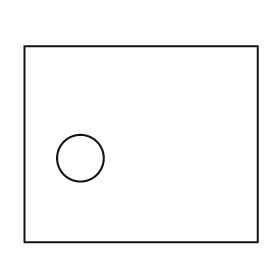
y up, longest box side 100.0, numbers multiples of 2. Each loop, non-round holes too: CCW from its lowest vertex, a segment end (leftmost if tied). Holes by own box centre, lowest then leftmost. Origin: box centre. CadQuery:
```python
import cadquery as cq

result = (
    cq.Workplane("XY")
    .moveTo(-50.0, -42.0)
    .lineTo(50.0, -42.0)
    .lineTo(50.0, 42.0)
    .lineTo(-50.0, 42.0)
    .close()
    .moveTo(-26.0, -6.0)
    .circle(10.0)
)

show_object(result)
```